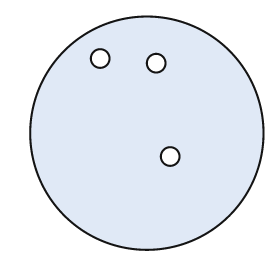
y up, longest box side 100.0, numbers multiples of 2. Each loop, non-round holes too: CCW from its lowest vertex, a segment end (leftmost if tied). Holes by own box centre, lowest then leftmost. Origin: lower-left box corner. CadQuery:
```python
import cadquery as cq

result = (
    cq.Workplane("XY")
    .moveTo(50.0, 50.0)
    .circle(50.0)
    .moveTo(60.0, 40.0)
    .circle(4.0)
    .moveTo(54.0, 80.0)
    .circle(4.0)
    .moveTo(30.0, 82.0)
    .circle(4.0)
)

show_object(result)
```